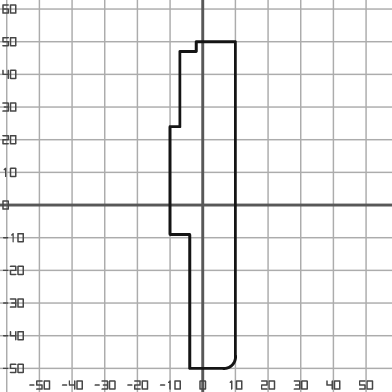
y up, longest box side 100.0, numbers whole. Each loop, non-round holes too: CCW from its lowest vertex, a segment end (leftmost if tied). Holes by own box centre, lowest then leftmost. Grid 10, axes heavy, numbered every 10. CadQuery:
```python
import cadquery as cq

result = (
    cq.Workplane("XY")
    .moveTo(-4.0, -50.0)
    .lineTo(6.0, -50.0)
    .threePointArc((9.0, -49.0), (10.0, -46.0))
    .lineTo(10.0, 50.0)
    .lineTo(-2.0, 50.0)
    .lineTo(-2.0, 47.0)
    .lineTo(-7.0, 47.0)
    .lineTo(-7.0, 24.0)
    .lineTo(-10.0, 24.0)
    .lineTo(-10.0, -9.0)
    .lineTo(-4.0, -9.0)
    .close()
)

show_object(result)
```